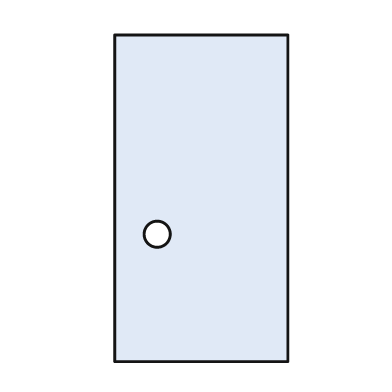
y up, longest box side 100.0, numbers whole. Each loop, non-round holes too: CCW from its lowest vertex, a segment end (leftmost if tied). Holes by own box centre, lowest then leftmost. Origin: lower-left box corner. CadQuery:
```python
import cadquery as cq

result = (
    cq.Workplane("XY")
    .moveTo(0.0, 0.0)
    .lineTo(53.0, 0.0)
    .lineTo(53.0, 100.0)
    .lineTo(0.0, 100.0)
    .close()
    .moveTo(13.0, 39.0)
    .circle(4.0)
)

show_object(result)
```